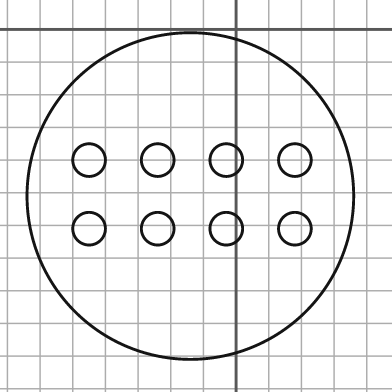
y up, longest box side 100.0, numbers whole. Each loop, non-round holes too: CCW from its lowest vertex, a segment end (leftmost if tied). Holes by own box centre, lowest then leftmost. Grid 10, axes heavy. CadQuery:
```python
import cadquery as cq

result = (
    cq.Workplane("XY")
    .moveTo(-14.0, -51.0)
    .circle(50.0)
    .moveTo(-45.0, -61.0)
    .circle(5.0)
    .moveTo(-24.0, -61.0)
    .circle(5.0)
    .moveTo(-3.0, -61.0)
    .circle(5.0)
    .moveTo(18.0, -61.0)
    .circle(5.0)
    .moveTo(-45.0, -40.0)
    .circle(5.0)
    .moveTo(-24.0, -40.0)
    .circle(5.0)
    .moveTo(-3.0, -40.0)
    .circle(5.0)
    .moveTo(18.0, -40.0)
    .circle(5.0)
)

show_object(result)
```